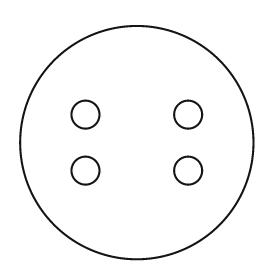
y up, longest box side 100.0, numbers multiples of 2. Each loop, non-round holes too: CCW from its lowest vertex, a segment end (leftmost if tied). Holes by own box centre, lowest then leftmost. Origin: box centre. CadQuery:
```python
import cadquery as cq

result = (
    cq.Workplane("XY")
    .moveTo(0.0, 0.0)
    .circle(50.0)
    .moveTo(-22.0, -12.0)
    .circle(6.0)
    .moveTo(22.0, -12.0)
    .circle(6.0)
    .moveTo(-22.0, 12.0)
    .circle(6.0)
    .moveTo(22.0, 12.0)
    .circle(6.0)
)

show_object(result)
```